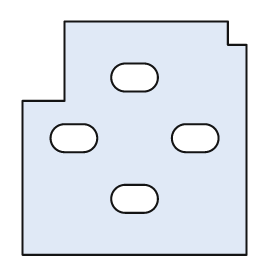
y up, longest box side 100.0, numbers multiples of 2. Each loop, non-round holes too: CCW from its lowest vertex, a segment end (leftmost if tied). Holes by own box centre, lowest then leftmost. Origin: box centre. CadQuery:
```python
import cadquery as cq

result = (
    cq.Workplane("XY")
    .moveTo(-48.0, -50.0)
    .lineTo(48.0, -50.0)
    .lineTo(48.0, 40.0)
    .lineTo(40.0, 40.0)
    .lineTo(40.0, 50.0)
    .lineTo(-30.0, 50.0)
    .lineTo(-30.0, 16.0)
    .lineTo(-48.0, 16.0)
    .close()
    .moveTo(-4.0, -32.0)
    .lineTo(4.0, -32.0)
    .threePointArc((10.0, -26.0), (4.0, -20.0))
    .lineTo(-4.0, -20.0)
    .threePointArc((-10.0, -26.0), (-4.0, -32.0))
    .close()
    .moveTo(-30.0, -6.0)
    .lineTo(-22.0, -6.0)
    .threePointArc((-16.0, 0.0), (-22.0, 6.0))
    .lineTo(-30.0, 6.0)
    .threePointArc((-36.0, 0.0), (-30.0, -6.0))
    .close()
    .moveTo(22.0, -6.0)
    .lineTo(30.0, -6.0)
    .threePointArc((36.0, 0.0), (30.0, 6.0))
    .lineTo(22.0, 6.0)
    .threePointArc((16.0, 0.0), (22.0, -6.0))
    .close()
    .moveTo(-4.0, 20.0)
    .lineTo(4.0, 20.0)
    .threePointArc((10.0, 26.0), (4.0, 32.0))
    .lineTo(-4.0, 32.0)
    .threePointArc((-10.0, 26.0), (-4.0, 20.0))
    .close()
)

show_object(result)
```